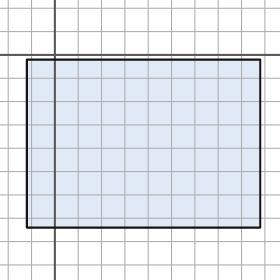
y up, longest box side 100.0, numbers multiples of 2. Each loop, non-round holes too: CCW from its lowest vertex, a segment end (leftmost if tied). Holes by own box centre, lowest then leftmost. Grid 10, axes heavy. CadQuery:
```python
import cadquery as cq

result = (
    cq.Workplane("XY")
    .moveTo(-12.0, -74.0)
    .lineTo(88.0, -74.0)
    .lineTo(88.0, -2.0)
    .lineTo(-12.0, -2.0)
    .close()
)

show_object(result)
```